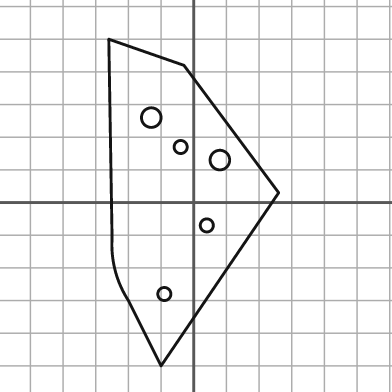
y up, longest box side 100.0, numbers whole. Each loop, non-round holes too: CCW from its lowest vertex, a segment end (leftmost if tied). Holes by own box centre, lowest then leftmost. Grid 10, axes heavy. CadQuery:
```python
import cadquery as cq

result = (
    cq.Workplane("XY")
    .moveTo(-10.0, -50.0)
    .lineTo(26.0, 3.0)
    .lineTo(-3.0, 42.0)
    .lineTo(-26.0, 50.0)
    .lineTo(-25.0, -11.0)
    .threePointArc((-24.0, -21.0), (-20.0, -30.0))
    .close()
    .moveTo(-9.0, -28.0)
    .circle(2.0)
    .moveTo(4.0, -7.0)
    .circle(2.0)
    .moveTo(8.0, 13.0)
    .circle(3.0)
    .moveTo(-4.0, 17.0)
    .circle(2.0)
    .moveTo(-13.0, 26.0)
    .circle(3.0)
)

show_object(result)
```